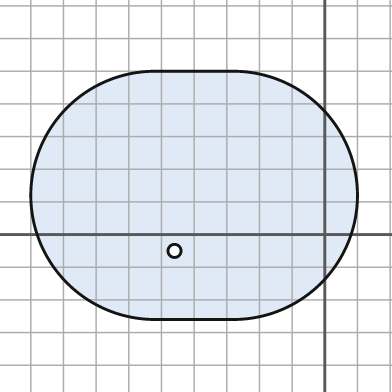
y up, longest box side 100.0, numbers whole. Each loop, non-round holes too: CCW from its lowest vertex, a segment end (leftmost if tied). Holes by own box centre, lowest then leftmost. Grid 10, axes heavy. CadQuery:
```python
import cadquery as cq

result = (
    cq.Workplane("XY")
    .moveTo(-52.0, -26.0)
    .lineTo(-28.0, -26.0)
    .threePointArc((10.0, 12.0), (-28.0, 50.0))
    .lineTo(-52.0, 50.0)
    .threePointArc((-90.0, 12.0), (-52.0, -26.0))
    .close()
    .moveTo(-46.0, -5.0)
    .circle(2.0)
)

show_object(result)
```